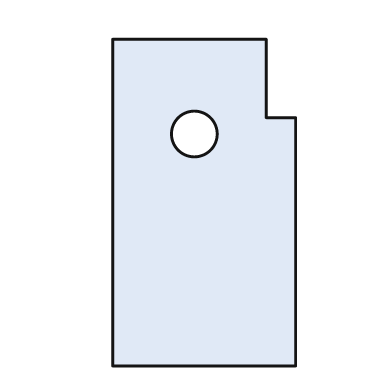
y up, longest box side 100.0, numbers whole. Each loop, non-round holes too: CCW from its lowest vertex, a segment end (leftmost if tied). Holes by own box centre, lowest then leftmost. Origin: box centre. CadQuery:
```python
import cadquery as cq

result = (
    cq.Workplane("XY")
    .moveTo(-28.0, -50.0)
    .lineTo(28.0, -50.0)
    .lineTo(28.0, 26.0)
    .lineTo(19.0, 26.0)
    .lineTo(19.0, 50.0)
    .lineTo(-28.0, 50.0)
    .close()
    .moveTo(-3.0, 21.0)
    .circle(7.0)
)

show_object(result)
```